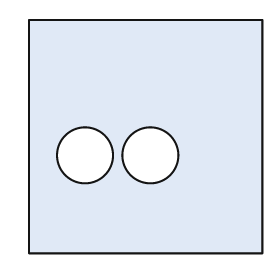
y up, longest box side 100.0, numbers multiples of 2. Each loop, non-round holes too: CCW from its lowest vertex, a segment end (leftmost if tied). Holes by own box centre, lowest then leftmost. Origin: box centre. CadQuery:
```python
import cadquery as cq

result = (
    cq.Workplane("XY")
    .moveTo(-50.0, -50.0)
    .lineTo(50.0, -50.0)
    .lineTo(50.0, 50.0)
    .lineTo(-50.0, 50.0)
    .close()
    .moveTo(-26.0, -8.0)
    .circle(12.0)
    .moveTo(2.0, -8.0)
    .circle(12.0)
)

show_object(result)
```